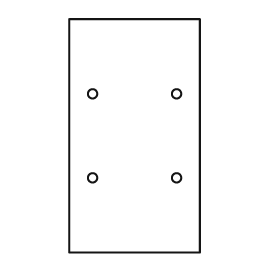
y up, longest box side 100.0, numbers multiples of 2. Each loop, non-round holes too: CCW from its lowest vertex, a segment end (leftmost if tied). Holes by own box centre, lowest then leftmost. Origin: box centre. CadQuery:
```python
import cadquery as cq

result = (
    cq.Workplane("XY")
    .moveTo(-28.0, -50.0)
    .lineTo(28.0, -50.0)
    .lineTo(28.0, 50.0)
    .lineTo(-28.0, 50.0)
    .close()
    .moveTo(-18.0, -18.0)
    .circle(2.0)
    .moveTo(18.0, -18.0)
    .circle(2.0)
    .moveTo(-18.0, 18.0)
    .circle(2.0)
    .moveTo(18.0, 18.0)
    .circle(2.0)
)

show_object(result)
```